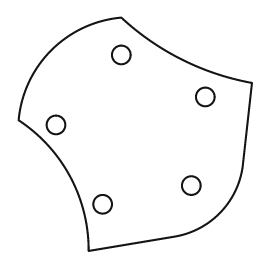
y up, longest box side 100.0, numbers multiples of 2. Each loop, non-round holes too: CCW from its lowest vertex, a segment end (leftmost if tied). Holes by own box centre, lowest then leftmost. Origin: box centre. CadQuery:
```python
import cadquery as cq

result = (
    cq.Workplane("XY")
    .moveTo(-20.0, -50.0)
    .lineTo(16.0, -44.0)
    .threePointArc((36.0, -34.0), (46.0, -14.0))
    .lineTo(50.0, 22.0)
    .threePointArc((20.0, 32.0), (-6.0, 50.0))
    .threePointArc((-36.0, 36.0), (-50.0, 6.0))
    .threePointArc((-28.0, -18.0), (-20.0, -50.0))
    .close()
    .moveTo(-14.0, -30.0)
    .circle(4.0)
    .moveTo(24.0, -22.0)
    .circle(4.0)
    .moveTo(-34.0, 4.0)
    .circle(4.0)
    .moveTo(30.0, 16.0)
    .circle(4.0)
    .moveTo(-6.0, 34.0)
    .circle(4.0)
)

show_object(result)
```